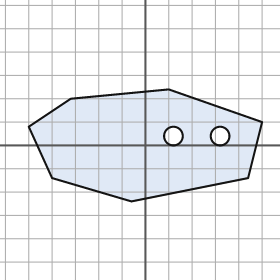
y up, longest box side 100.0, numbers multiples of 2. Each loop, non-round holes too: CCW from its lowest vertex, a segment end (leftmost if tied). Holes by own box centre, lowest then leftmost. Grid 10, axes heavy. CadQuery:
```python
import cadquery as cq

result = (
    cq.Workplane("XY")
    .moveTo(-6.0, -24.0)
    .lineTo(44.0, -14.0)
    .lineTo(50.0, 10.0)
    .lineTo(10.0, 24.0)
    .lineTo(-32.0, 20.0)
    .lineTo(-50.0, 8.0)
    .lineTo(-40.0, -14.0)
    .close()
    .moveTo(12.0, 4.0)
    .circle(4.0)
    .moveTo(32.0, 4.0)
    .circle(4.0)
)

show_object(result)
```